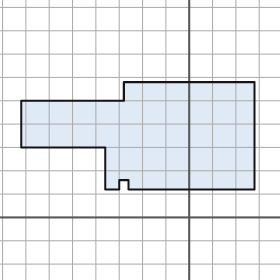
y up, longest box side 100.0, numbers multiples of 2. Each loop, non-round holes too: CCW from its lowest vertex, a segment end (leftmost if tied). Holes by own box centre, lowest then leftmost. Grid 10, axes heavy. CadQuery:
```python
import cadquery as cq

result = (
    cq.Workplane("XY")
    .moveTo(-36.0, 12.0)
    .lineTo(-30.0, 12.0)
    .lineTo(-30.0, 16.0)
    .lineTo(-26.0, 16.0)
    .lineTo(-26.0, 12.0)
    .lineTo(28.0, 12.0)
    .lineTo(28.0, 58.0)
    .lineTo(-28.0, 58.0)
    .lineTo(-28.0, 50.0)
    .lineTo(-72.0, 50.0)
    .lineTo(-72.0, 30.0)
    .lineTo(-36.0, 30.0)
    .close()
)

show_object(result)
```